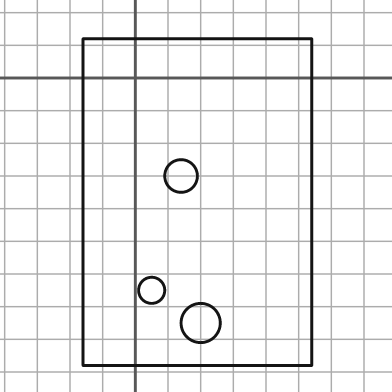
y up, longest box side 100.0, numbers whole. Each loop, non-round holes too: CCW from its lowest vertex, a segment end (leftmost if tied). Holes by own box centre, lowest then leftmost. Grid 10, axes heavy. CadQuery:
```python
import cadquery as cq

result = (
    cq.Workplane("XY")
    .moveTo(-16.0, -88.0)
    .lineTo(54.0, -88.0)
    .lineTo(54.0, 12.0)
    .lineTo(-16.0, 12.0)
    .close()
    .moveTo(20.0, -75.0)
    .circle(6.0)
    .moveTo(5.0, -65.0)
    .circle(4.0)
    .moveTo(14.0, -30.0)
    .circle(5.0)
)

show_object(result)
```